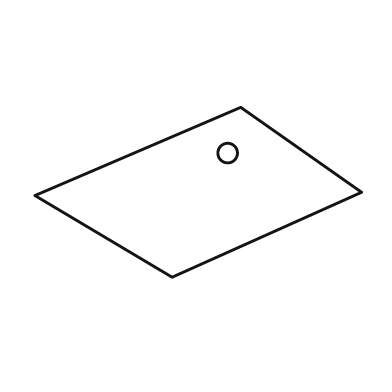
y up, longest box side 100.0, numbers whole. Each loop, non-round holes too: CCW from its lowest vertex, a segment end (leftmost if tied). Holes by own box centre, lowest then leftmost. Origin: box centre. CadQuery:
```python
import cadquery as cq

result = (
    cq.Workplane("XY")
    .moveTo(-8.0, -26.0)
    .lineTo(50.0, 0.0)
    .lineTo(13.0, 26.0)
    .lineTo(-50.0, -1.0)
    .close()
    .moveTo(9.0, 12.0)
    .circle(3.0)
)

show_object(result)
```